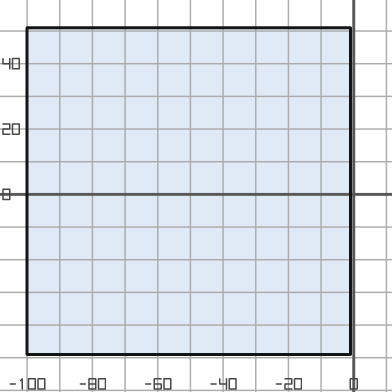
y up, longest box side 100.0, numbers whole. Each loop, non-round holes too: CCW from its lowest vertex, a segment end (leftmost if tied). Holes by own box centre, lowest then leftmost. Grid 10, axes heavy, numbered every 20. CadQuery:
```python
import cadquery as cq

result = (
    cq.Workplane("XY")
    .moveTo(-100.0, -49.0)
    .lineTo(-1.0, -49.0)
    .lineTo(-1.0, 51.0)
    .lineTo(-100.0, 51.0)
    .close()
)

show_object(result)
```